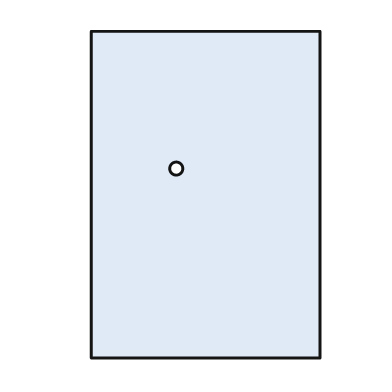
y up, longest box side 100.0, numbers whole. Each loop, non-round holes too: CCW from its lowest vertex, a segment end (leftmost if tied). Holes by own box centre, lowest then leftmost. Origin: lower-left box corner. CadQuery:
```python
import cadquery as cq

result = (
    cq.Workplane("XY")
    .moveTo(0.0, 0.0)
    .lineTo(70.0, 0.0)
    .lineTo(70.0, 100.0)
    .lineTo(0.0, 100.0)
    .close()
    .moveTo(26.0, 58.0)
    .circle(2.0)
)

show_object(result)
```